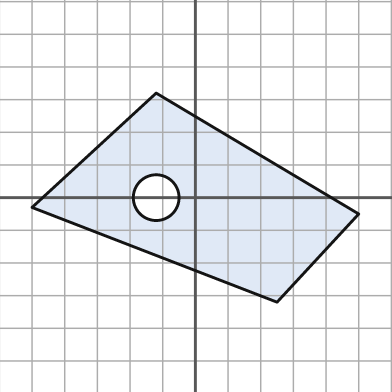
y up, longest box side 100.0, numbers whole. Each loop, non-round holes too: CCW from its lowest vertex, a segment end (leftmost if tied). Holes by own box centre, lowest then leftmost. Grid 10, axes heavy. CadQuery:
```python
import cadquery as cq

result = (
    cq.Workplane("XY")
    .moveTo(25.0, -32.0)
    .lineTo(50.0, -5.0)
    .lineTo(-12.0, 32.0)
    .lineTo(-50.0, -3.0)
    .close()
    .moveTo(-12.0, 0.0)
    .circle(7.0)
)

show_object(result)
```